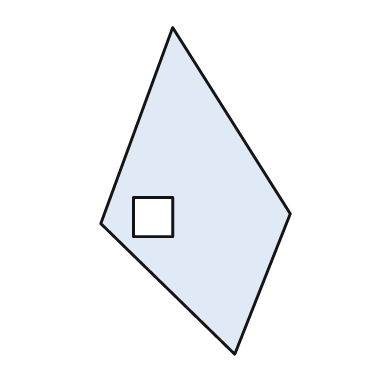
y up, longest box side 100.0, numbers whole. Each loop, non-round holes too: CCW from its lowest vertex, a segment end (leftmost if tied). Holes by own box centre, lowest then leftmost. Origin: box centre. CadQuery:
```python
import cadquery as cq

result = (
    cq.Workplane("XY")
    .moveTo(12.0, -50.0)
    .lineTo(29.0, -7.0)
    .lineTo(-7.0, 50.0)
    .lineTo(-29.0, -10.0)
    .close()
    .moveTo(-19.0, -14.0)
    .lineTo(-7.0, -14.0)
    .lineTo(-7.0, -2.0)
    .lineTo(-19.0, -2.0)
    .close()
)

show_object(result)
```